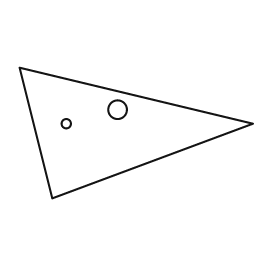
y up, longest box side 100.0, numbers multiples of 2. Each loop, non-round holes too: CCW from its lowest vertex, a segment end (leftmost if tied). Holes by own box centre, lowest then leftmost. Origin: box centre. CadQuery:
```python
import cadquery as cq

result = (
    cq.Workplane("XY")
    .moveTo(-36.0, -28.0)
    .lineTo(50.0, 4.0)
    .lineTo(-50.0, 28.0)
    .close()
    .moveTo(-30.0, 4.0)
    .circle(2.0)
    .moveTo(-8.0, 10.0)
    .circle(4.0)
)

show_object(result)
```